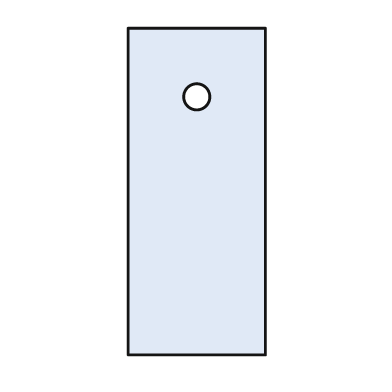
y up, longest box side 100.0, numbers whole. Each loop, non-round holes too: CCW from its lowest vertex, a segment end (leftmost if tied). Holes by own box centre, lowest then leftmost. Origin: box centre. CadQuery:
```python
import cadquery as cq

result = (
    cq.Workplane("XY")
    .moveTo(-21.0, -50.0)
    .lineTo(21.0, -50.0)
    .lineTo(21.0, 50.0)
    .lineTo(-21.0, 50.0)
    .close()
    .moveTo(0.0, 29.0)
    .circle(4.0)
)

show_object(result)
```